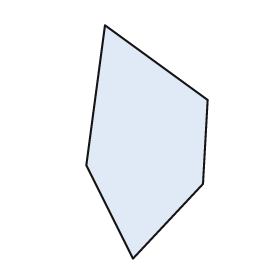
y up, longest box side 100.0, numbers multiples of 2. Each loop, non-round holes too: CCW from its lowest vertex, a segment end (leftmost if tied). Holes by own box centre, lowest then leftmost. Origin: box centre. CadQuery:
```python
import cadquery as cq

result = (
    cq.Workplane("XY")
    .moveTo(-6.0, -50.0)
    .lineTo(24.0, -18.0)
    .lineTo(26.0, 18.0)
    .lineTo(-18.0, 50.0)
    .lineTo(-26.0, -10.0)
    .close()
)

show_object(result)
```